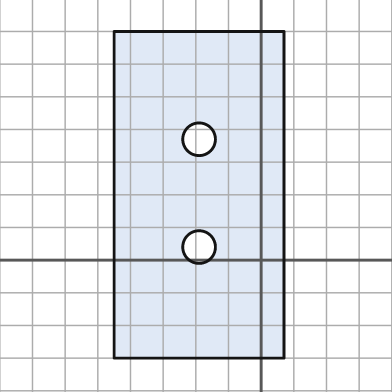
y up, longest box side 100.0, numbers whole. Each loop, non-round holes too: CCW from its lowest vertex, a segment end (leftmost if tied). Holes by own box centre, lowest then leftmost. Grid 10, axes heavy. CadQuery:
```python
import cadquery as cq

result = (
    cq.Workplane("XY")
    .moveTo(-45.0, -30.0)
    .lineTo(7.0, -30.0)
    .lineTo(7.0, 70.0)
    .lineTo(-45.0, 70.0)
    .close()
    .moveTo(-19.0, 4.0)
    .circle(5.0)
    .moveTo(-19.0, 37.0)
    .circle(5.0)
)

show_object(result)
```